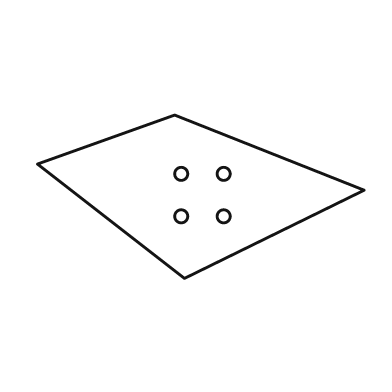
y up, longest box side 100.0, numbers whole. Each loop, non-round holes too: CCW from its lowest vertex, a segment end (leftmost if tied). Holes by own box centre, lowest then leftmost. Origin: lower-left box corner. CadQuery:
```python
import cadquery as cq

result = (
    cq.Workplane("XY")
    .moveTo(45.0, 0.0)
    .lineTo(100.0, 27.0)
    .lineTo(42.0, 50.0)
    .lineTo(0.0, 35.0)
    .close()
    .moveTo(44.0, 19.0)
    .circle(2.0)
    .moveTo(57.0, 19.0)
    .circle(2.0)
    .moveTo(44.0, 32.0)
    .circle(2.0)
    .moveTo(57.0, 32.0)
    .circle(2.0)
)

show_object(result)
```